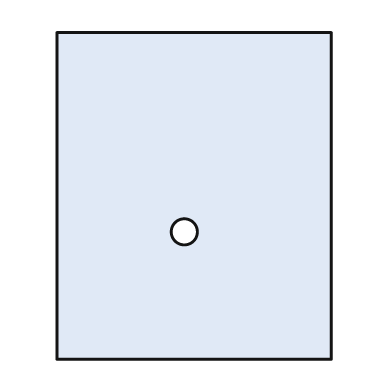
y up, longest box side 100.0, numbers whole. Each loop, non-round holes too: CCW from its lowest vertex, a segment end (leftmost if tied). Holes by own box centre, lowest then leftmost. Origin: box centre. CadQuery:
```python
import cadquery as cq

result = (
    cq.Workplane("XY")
    .moveTo(-42.0, -50.0)
    .lineTo(42.0, -50.0)
    .lineTo(42.0, 50.0)
    .lineTo(-42.0, 50.0)
    .close()
    .moveTo(-3.0, -11.0)
    .circle(4.0)
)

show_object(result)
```